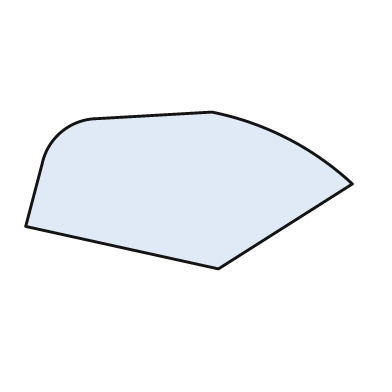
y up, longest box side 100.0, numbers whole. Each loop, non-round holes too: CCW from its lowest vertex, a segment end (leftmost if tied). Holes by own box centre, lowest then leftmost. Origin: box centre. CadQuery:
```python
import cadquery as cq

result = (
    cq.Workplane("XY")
    .moveTo(9.0, -24.0)
    .lineTo(50.0, 2.0)
    .threePointArc((30.0, 16.0), (7.0, 24.0))
    .lineTo(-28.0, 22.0)
    .threePointArc((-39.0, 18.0), (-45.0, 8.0))
    .lineTo(-50.0, -11.0)
    .close()
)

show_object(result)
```